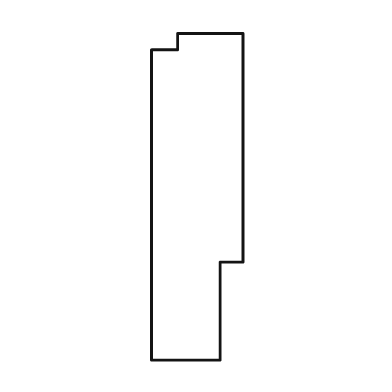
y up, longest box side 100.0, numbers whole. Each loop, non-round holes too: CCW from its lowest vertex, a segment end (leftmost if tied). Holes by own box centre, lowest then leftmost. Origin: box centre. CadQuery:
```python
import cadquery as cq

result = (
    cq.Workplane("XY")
    .moveTo(-14.0, -50.0)
    .lineTo(7.0, -50.0)
    .lineTo(7.0, -20.0)
    .lineTo(14.0, -20.0)
    .lineTo(14.0, 50.0)
    .lineTo(-6.0, 50.0)
    .lineTo(-6.0, 45.0)
    .lineTo(-14.0, 45.0)
    .close()
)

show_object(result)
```